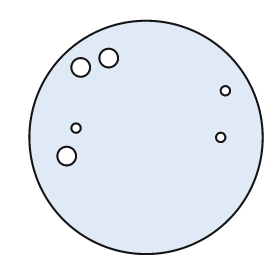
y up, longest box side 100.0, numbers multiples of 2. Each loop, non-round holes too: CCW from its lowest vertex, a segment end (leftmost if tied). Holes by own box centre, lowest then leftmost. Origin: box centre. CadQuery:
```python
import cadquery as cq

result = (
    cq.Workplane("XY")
    .moveTo(0.0, 0.0)
    .circle(50.0)
    .moveTo(-34.0, -8.0)
    .circle(4.0)
    .moveTo(32.0, 0.0)
    .circle(2.0)
    .moveTo(-30.0, 4.0)
    .circle(2.0)
    .moveTo(34.0, 20.0)
    .circle(2.0)
    .moveTo(-28.0, 30.0)
    .circle(4.0)
    .moveTo(-16.0, 34.0)
    .circle(4.0)
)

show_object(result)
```